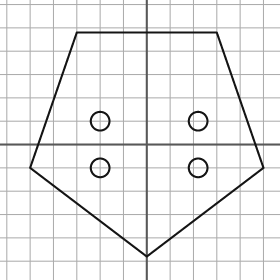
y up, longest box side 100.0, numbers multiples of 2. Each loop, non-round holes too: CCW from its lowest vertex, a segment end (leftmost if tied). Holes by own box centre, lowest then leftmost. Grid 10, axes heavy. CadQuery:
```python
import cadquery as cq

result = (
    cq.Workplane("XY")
    .moveTo(0.0, -48.0)
    .lineTo(50.0, -10.0)
    .lineTo(30.0, 48.0)
    .lineTo(-30.0, 48.0)
    .lineTo(-50.0, -10.0)
    .close()
    .moveTo(-20.0, -10.0)
    .circle(4.0)
    .moveTo(22.0, -10.0)
    .circle(4.0)
    .moveTo(-20.0, 10.0)
    .circle(4.0)
    .moveTo(22.0, 10.0)
    .circle(4.0)
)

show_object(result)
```